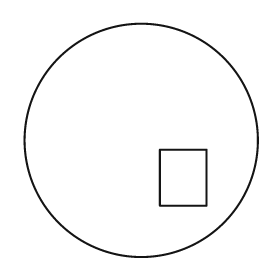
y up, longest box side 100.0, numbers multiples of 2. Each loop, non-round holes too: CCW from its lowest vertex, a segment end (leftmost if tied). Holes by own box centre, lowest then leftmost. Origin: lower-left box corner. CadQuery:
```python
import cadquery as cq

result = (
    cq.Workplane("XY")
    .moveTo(50.0, 50.0)
    .circle(50.0)
    .moveTo(58.0, 22.0)
    .lineTo(78.0, 22.0)
    .lineTo(78.0, 46.0)
    .lineTo(58.0, 46.0)
    .close()
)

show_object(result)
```